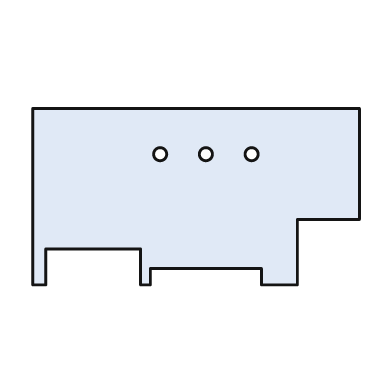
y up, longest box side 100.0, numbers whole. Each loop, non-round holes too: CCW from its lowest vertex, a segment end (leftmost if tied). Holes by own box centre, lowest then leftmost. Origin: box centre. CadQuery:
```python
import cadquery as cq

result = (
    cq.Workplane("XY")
    .moveTo(-50.0, -27.0)
    .lineTo(-46.0, -27.0)
    .lineTo(-46.0, -16.0)
    .lineTo(-17.0, -16.0)
    .lineTo(-17.0, -27.0)
    .lineTo(-14.0, -27.0)
    .lineTo(-14.0, -22.0)
    .lineTo(20.0, -22.0)
    .lineTo(20.0, -27.0)
    .lineTo(31.0, -27.0)
    .lineTo(31.0, -7.0)
    .lineTo(50.0, -7.0)
    .lineTo(50.0, 27.0)
    .lineTo(-50.0, 27.0)
    .close()
    .moveTo(-11.0, 13.0)
    .circle(2.0)
    .moveTo(3.0, 13.0)
    .circle(2.0)
    .moveTo(17.0, 13.0)
    .circle(2.0)
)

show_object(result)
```